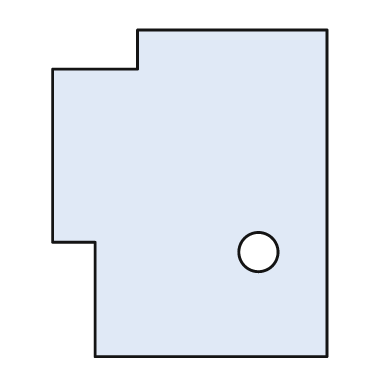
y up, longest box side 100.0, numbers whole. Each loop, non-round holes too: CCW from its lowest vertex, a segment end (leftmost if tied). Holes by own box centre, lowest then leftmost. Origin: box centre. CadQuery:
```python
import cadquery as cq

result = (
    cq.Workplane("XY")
    .moveTo(-29.0, -50.0)
    .lineTo(42.0, -50.0)
    .lineTo(42.0, 50.0)
    .lineTo(-16.0, 50.0)
    .lineTo(-16.0, 38.0)
    .lineTo(-42.0, 38.0)
    .lineTo(-42.0, -15.0)
    .lineTo(-29.0, -15.0)
    .close()
    .moveTo(21.0, -18.0)
    .circle(6.0)
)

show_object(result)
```